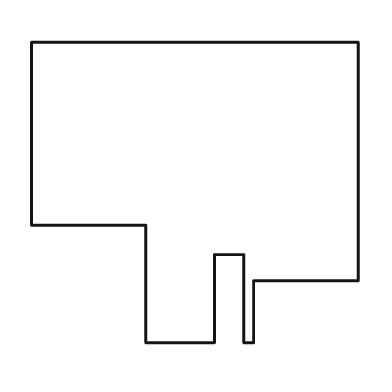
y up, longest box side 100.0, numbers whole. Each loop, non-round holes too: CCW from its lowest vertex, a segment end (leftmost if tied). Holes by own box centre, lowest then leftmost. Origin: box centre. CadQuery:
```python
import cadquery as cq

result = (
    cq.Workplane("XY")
    .moveTo(-15.0, -46.0)
    .lineTo(6.0, -46.0)
    .lineTo(6.0, -19.0)
    .lineTo(15.0, -19.0)
    .lineTo(15.0, -46.0)
    .lineTo(18.0, -46.0)
    .lineTo(18.0, -27.0)
    .lineTo(50.0, -27.0)
    .lineTo(50.0, 46.0)
    .lineTo(-50.0, 46.0)
    .lineTo(-50.0, -10.0)
    .lineTo(-15.0, -10.0)
    .close()
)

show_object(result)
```